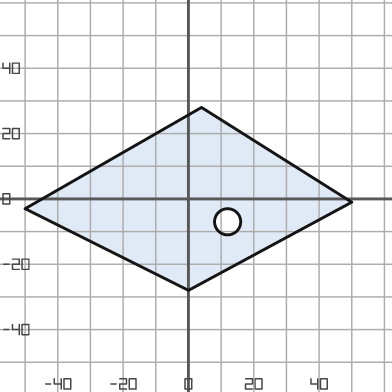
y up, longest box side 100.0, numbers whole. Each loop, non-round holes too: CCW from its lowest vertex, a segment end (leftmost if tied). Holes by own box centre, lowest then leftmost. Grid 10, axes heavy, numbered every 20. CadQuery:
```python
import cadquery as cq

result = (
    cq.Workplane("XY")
    .moveTo(0.0, -28.0)
    .lineTo(50.0, -1.0)
    .lineTo(4.0, 28.0)
    .lineTo(-50.0, -3.0)
    .close()
    .moveTo(12.0, -7.0)
    .circle(4.0)
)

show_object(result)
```